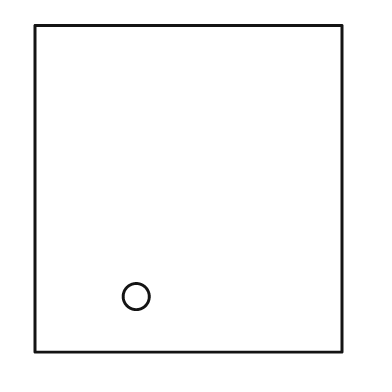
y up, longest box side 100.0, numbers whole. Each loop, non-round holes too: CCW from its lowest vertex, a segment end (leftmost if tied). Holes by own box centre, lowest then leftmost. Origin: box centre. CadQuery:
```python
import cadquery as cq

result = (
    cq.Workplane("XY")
    .moveTo(-47.0, -50.0)
    .lineTo(47.0, -50.0)
    .lineTo(47.0, 50.0)
    .lineTo(-47.0, 50.0)
    .close()
    .moveTo(-16.0, -33.0)
    .circle(4.0)
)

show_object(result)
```